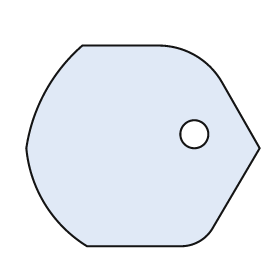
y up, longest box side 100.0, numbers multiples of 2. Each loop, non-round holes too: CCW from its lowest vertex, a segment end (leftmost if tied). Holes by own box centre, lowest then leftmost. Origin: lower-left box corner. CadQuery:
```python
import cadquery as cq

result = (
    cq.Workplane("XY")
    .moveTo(26.0, 0.0)
    .lineTo(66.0, 0.0)
    .threePointArc((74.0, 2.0), (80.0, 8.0))
    .lineTo(100.0, 42.0)
    .lineTo(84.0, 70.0)
    .threePointArc((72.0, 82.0), (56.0, 86.0))
    .lineTo(24.0, 86.0)
    .threePointArc((8.0, 66.0), (0.0, 42.0))
    .threePointArc((8.0, 18.0), (26.0, 0.0))
    .close()
    .moveTo(72.0, 48.0)
    .circle(6.0)
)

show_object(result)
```